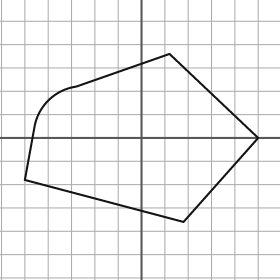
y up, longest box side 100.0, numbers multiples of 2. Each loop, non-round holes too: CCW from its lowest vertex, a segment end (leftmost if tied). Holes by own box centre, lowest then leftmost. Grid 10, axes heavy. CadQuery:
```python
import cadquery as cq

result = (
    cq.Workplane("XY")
    .moveTo(18.0, -36.0)
    .lineTo(50.0, 0.0)
    .lineTo(12.0, 36.0)
    .lineTo(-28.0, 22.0)
    .threePointArc((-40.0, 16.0), (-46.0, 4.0))
    .lineTo(-50.0, -18.0)
    .close()
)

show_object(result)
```